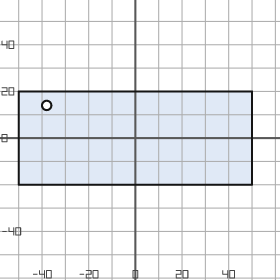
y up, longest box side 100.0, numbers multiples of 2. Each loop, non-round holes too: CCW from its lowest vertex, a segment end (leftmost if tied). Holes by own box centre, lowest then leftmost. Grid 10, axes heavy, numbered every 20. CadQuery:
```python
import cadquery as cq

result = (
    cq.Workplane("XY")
    .moveTo(-50.0, -20.0)
    .lineTo(50.0, -20.0)
    .lineTo(50.0, 20.0)
    .lineTo(-50.0, 20.0)
    .close()
    .moveTo(-38.0, 14.0)
    .circle(2.0)
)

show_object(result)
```